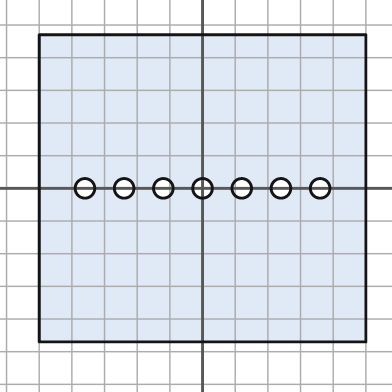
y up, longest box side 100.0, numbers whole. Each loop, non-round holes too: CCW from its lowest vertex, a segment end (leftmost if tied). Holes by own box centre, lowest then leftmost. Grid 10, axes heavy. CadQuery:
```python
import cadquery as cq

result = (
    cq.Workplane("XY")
    .moveTo(-50.0, -47.0)
    .lineTo(50.0, -47.0)
    .lineTo(50.0, 47.0)
    .lineTo(-50.0, 47.0)
    .close()
    .moveTo(-36.0, 0.0)
    .circle(3.0)
    .moveTo(-24.0, 0.0)
    .circle(3.0)
    .moveTo(-12.0, 0.0)
    .circle(3.0)
    .moveTo(0.0, 0.0)
    .circle(3.0)
    .moveTo(12.0, 0.0)
    .circle(3.0)
    .moveTo(24.0, 0.0)
    .circle(3.0)
    .moveTo(36.0, 0.0)
    .circle(3.0)
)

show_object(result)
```